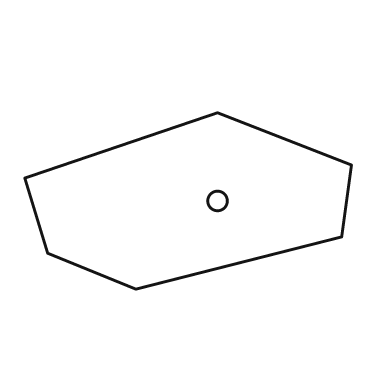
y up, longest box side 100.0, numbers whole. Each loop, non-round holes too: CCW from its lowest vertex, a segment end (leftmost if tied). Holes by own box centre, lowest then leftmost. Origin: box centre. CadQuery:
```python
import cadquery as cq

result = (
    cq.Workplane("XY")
    .moveTo(-16.0, -27.0)
    .lineTo(47.0, -11.0)
    .lineTo(50.0, 11.0)
    .lineTo(9.0, 27.0)
    .lineTo(-50.0, 7.0)
    .lineTo(-43.0, -16.0)
    .close()
    .moveTo(9.0, 0.0)
    .circle(3.0)
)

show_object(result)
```